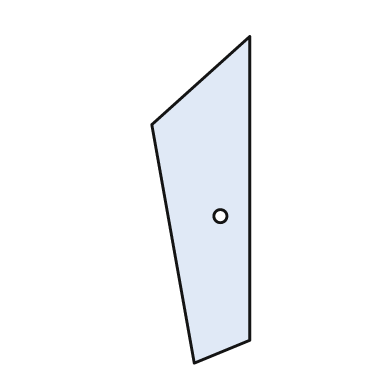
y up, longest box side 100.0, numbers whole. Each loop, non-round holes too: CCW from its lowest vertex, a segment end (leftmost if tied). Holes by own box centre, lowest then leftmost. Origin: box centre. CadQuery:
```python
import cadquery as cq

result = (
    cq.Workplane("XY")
    .moveTo(-2.0, -50.0)
    .lineTo(15.0, -43.0)
    .lineTo(15.0, 50.0)
    .lineTo(-15.0, 23.0)
    .close()
    .moveTo(6.0, -5.0)
    .circle(2.0)
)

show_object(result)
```